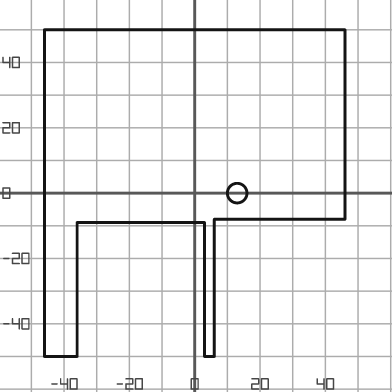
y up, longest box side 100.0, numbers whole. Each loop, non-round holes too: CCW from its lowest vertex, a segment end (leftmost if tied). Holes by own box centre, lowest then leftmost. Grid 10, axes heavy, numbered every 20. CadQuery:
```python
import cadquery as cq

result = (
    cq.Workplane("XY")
    .moveTo(-46.0, -50.0)
    .lineTo(-36.0, -50.0)
    .lineTo(-36.0, -9.0)
    .lineTo(3.0, -9.0)
    .lineTo(3.0, -50.0)
    .lineTo(6.0, -50.0)
    .lineTo(6.0, -8.0)
    .lineTo(46.0, -8.0)
    .lineTo(46.0, 50.0)
    .lineTo(-46.0, 50.0)
    .close()
    .moveTo(13.0, 0.0)
    .circle(3.0)
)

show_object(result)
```